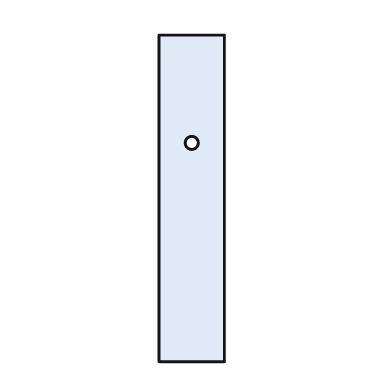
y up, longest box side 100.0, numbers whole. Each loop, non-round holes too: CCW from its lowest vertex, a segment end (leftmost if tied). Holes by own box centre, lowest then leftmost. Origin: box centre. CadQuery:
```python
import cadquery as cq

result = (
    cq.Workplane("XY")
    .moveTo(-10.0, -50.0)
    .lineTo(10.0, -50.0)
    .lineTo(10.0, 50.0)
    .lineTo(-10.0, 50.0)
    .close()
    .moveTo(0.0, 17.0)
    .circle(2.0)
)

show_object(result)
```